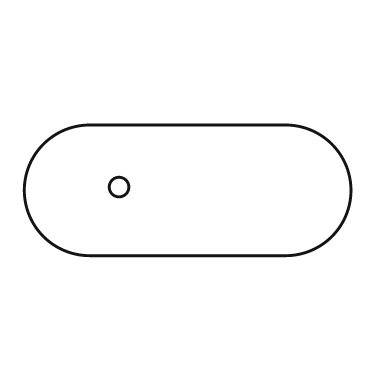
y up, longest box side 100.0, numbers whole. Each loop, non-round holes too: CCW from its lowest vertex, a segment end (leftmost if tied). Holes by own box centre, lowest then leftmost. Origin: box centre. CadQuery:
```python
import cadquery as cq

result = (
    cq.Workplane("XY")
    .moveTo(-30.0, -20.0)
    .lineTo(30.0, -20.0)
    .threePointArc((50.0, 0.0), (30.0, 20.0))
    .lineTo(-30.0, 20.0)
    .threePointArc((-50.0, 0.0), (-30.0, -20.0))
    .close()
    .moveTo(-21.0, 1.0)
    .circle(3.0)
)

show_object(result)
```